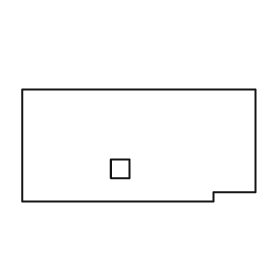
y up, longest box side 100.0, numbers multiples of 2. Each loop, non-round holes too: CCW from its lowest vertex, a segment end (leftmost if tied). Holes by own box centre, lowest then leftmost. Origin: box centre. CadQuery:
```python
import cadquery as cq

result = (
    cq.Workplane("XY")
    .moveTo(-50.0, -24.0)
    .lineTo(32.0, -24.0)
    .lineTo(32.0, -20.0)
    .lineTo(50.0, -20.0)
    .lineTo(50.0, 24.0)
    .lineTo(-50.0, 24.0)
    .close()
    .moveTo(-12.0, -14.0)
    .lineTo(-4.0, -14.0)
    .lineTo(-4.0, -6.0)
    .lineTo(-12.0, -6.0)
    .close()
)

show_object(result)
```